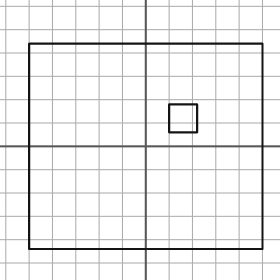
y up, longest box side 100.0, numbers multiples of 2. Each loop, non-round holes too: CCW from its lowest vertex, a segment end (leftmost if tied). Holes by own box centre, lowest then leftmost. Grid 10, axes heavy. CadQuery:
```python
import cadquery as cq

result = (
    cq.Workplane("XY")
    .moveTo(-50.0, -44.0)
    .lineTo(50.0, -44.0)
    .lineTo(50.0, 44.0)
    .lineTo(-50.0, 44.0)
    .close()
    .moveTo(10.0, 6.0)
    .lineTo(22.0, 6.0)
    .lineTo(22.0, 18.0)
    .lineTo(10.0, 18.0)
    .close()
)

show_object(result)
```